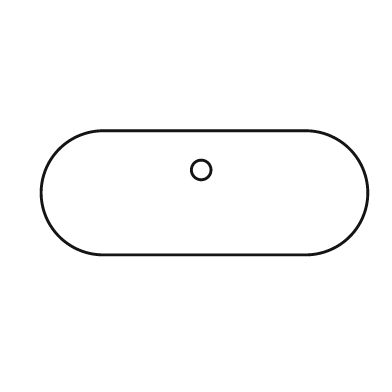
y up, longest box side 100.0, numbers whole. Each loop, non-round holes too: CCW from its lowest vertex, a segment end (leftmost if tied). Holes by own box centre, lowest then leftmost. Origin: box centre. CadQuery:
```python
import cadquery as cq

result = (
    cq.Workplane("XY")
    .moveTo(-31.0, -19.0)
    .lineTo(31.0, -19.0)
    .threePointArc((50.0, 0.0), (31.0, 19.0))
    .lineTo(-31.0, 19.0)
    .threePointArc((-50.0, 0.0), (-31.0, -19.0))
    .close()
    .moveTo(-1.0, 7.0)
    .circle(3.0)
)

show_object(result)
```